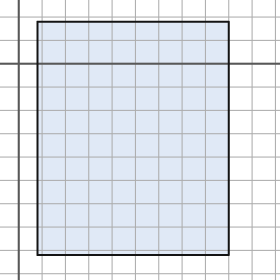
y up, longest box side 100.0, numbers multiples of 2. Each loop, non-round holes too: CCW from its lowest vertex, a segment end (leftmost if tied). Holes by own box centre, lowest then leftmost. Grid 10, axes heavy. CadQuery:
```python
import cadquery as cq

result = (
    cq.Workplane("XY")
    .moveTo(8.0, -82.0)
    .lineTo(90.0, -82.0)
    .lineTo(90.0, 18.0)
    .lineTo(8.0, 18.0)
    .close()
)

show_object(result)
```